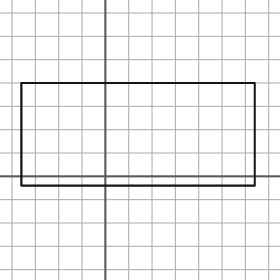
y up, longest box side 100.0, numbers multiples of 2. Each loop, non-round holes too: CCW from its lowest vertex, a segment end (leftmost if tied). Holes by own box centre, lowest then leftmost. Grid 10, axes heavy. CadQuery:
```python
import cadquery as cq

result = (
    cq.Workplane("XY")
    .moveTo(-36.0, -4.0)
    .lineTo(64.0, -4.0)
    .lineTo(64.0, 40.0)
    .lineTo(-36.0, 40.0)
    .close()
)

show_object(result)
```